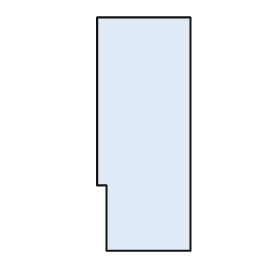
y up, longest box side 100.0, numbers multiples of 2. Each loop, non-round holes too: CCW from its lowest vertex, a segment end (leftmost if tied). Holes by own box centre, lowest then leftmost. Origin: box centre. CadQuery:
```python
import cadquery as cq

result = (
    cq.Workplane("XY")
    .moveTo(-16.0, -50.0)
    .lineTo(20.0, -50.0)
    .lineTo(20.0, 50.0)
    .lineTo(-20.0, 50.0)
    .lineTo(-20.0, -22.0)
    .lineTo(-16.0, -22.0)
    .close()
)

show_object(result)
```